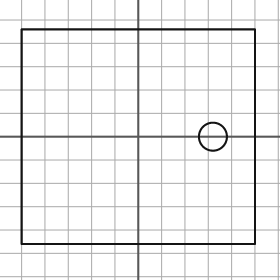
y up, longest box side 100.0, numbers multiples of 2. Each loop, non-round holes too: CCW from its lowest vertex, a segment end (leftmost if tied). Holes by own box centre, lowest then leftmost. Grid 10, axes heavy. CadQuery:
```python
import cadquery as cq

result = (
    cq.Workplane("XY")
    .moveTo(-50.0, -46.0)
    .lineTo(50.0, -46.0)
    .lineTo(50.0, 46.0)
    .lineTo(-50.0, 46.0)
    .close()
    .moveTo(32.0, 0.0)
    .circle(6.0)
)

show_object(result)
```